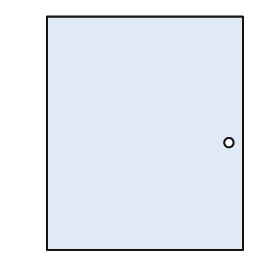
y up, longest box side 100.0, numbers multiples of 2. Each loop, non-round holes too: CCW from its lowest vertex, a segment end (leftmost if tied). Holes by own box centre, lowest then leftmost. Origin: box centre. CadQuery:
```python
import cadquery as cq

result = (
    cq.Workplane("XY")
    .moveTo(-42.0, -50.0)
    .lineTo(42.0, -50.0)
    .lineTo(42.0, 50.0)
    .lineTo(-42.0, 50.0)
    .close()
    .moveTo(36.0, -4.0)
    .circle(2.0)
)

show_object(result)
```